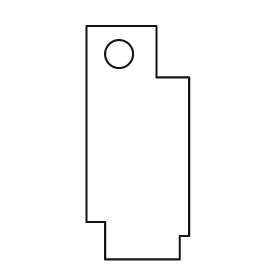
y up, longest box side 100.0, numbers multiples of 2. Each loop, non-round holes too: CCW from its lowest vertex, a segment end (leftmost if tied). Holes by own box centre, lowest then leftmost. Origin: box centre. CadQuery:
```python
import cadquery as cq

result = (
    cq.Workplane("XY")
    .moveTo(-14.0, -50.0)
    .lineTo(18.0, -50.0)
    .lineTo(18.0, -40.0)
    .lineTo(22.0, -40.0)
    .lineTo(22.0, 28.0)
    .lineTo(8.0, 28.0)
    .lineTo(8.0, 50.0)
    .lineTo(-22.0, 50.0)
    .lineTo(-22.0, -34.0)
    .lineTo(-14.0, -34.0)
    .close()
    .moveTo(-8.0, 38.0)
    .circle(6.0)
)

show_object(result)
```